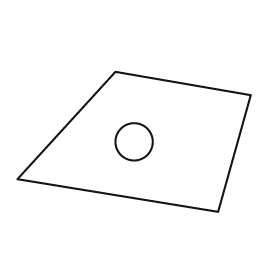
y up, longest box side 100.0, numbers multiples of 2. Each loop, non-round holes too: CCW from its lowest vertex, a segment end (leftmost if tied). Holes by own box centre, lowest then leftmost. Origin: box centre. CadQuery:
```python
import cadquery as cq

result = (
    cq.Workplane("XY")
    .moveTo(36.0, -30.0)
    .lineTo(50.0, 20.0)
    .lineTo(-8.0, 30.0)
    .lineTo(-50.0, -16.0)
    .close()
    .moveTo(0.0, 0.0)
    .circle(8.0)
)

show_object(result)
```